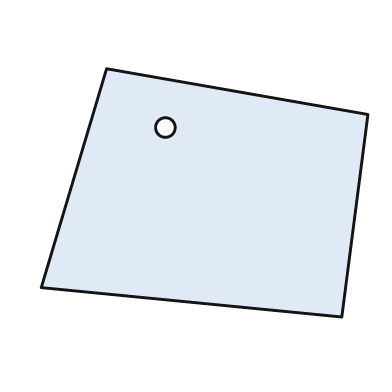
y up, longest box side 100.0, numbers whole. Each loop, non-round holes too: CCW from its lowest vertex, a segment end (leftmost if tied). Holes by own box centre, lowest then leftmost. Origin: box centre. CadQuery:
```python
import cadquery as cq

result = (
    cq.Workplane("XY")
    .moveTo(42.0, -38.0)
    .lineTo(50.0, 24.0)
    .lineTo(-30.0, 38.0)
    .lineTo(-50.0, -29.0)
    .close()
    .moveTo(-12.0, 20.0)
    .circle(3.0)
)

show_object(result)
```